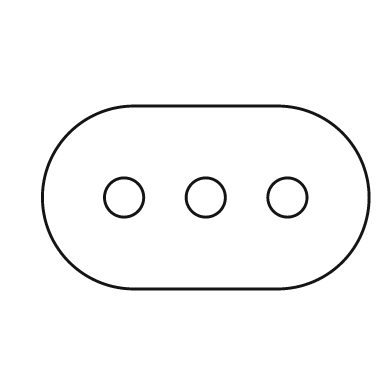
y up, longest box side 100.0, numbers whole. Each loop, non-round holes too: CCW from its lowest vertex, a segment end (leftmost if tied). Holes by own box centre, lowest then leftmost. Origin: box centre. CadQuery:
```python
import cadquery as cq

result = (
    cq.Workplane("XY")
    .moveTo(-22.0, -28.0)
    .lineTo(22.0, -28.0)
    .threePointArc((50.0, 0.0), (22.0, 28.0))
    .lineTo(-22.0, 28.0)
    .threePointArc((-50.0, 0.0), (-22.0, -28.0))
    .close()
    .moveTo(-25.0, 0.0)
    .circle(6.0)
    .moveTo(0.0, 0.0)
    .circle(6.0)
    .moveTo(25.0, 0.0)
    .circle(6.0)
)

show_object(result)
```